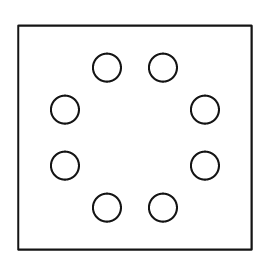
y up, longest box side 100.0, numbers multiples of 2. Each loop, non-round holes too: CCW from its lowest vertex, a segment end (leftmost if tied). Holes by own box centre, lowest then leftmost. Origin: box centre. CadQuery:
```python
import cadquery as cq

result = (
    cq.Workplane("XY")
    .moveTo(-50.0, -48.0)
    .lineTo(50.0, -48.0)
    .lineTo(50.0, 48.0)
    .lineTo(-50.0, 48.0)
    .close()
    .moveTo(-12.0, -30.0)
    .circle(6.0)
    .moveTo(12.0, -30.0)
    .circle(6.0)
    .moveTo(-30.0, -12.0)
    .circle(6.0)
    .moveTo(30.0, -12.0)
    .circle(6.0)
    .moveTo(-30.0, 12.0)
    .circle(6.0)
    .moveTo(30.0, 12.0)
    .circle(6.0)
    .moveTo(-12.0, 30.0)
    .circle(6.0)
    .moveTo(12.0, 30.0)
    .circle(6.0)
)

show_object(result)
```